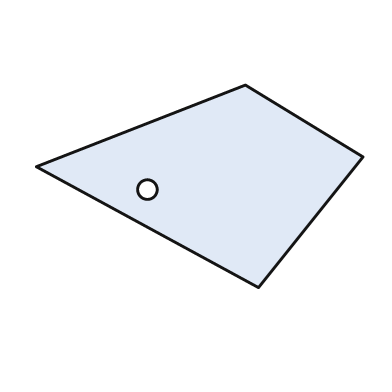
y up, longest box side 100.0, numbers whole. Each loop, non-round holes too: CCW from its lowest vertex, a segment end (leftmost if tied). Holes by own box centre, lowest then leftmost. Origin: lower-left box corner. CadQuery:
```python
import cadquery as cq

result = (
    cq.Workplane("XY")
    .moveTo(68.0, 0.0)
    .lineTo(100.0, 40.0)
    .lineTo(64.0, 62.0)
    .lineTo(0.0, 37.0)
    .close()
    .moveTo(34.0, 30.0)
    .circle(3.0)
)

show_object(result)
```